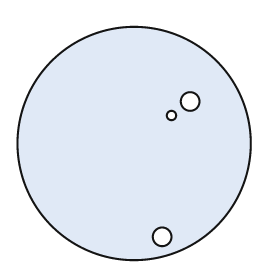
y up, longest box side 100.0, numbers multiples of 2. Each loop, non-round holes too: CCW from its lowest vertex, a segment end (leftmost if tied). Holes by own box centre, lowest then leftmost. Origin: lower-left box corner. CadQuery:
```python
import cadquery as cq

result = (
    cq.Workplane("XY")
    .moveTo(50.0, 50.0)
    .circle(50.0)
    .moveTo(62.0, 10.0)
    .circle(4.0)
    .moveTo(66.0, 62.0)
    .circle(2.0)
    .moveTo(74.0, 68.0)
    .circle(4.0)
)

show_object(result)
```